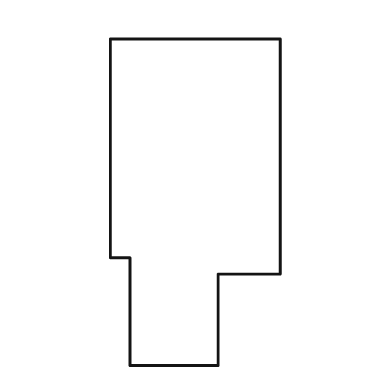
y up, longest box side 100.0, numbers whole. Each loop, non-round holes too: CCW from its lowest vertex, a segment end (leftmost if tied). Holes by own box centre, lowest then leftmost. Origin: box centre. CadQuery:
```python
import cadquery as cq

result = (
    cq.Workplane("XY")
    .moveTo(-20.0, -50.0)
    .lineTo(7.0, -50.0)
    .lineTo(7.0, -22.0)
    .lineTo(26.0, -22.0)
    .lineTo(26.0, 50.0)
    .lineTo(-26.0, 50.0)
    .lineTo(-26.0, -17.0)
    .lineTo(-20.0, -17.0)
    .close()
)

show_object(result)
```